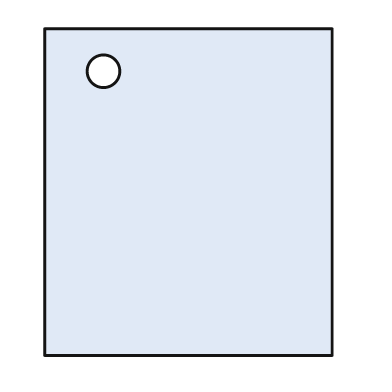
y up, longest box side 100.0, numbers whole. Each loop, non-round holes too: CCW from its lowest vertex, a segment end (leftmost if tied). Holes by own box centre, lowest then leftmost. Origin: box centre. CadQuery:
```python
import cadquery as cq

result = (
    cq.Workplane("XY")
    .moveTo(-44.0, -50.0)
    .lineTo(44.0, -50.0)
    .lineTo(44.0, 50.0)
    .lineTo(-44.0, 50.0)
    .close()
    .moveTo(-26.0, 37.0)
    .circle(5.0)
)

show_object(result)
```